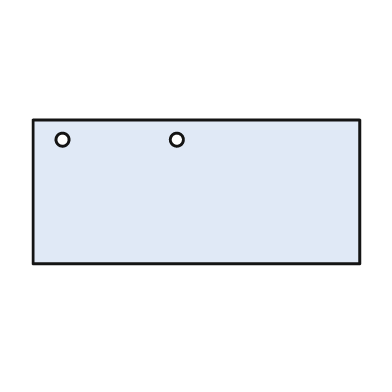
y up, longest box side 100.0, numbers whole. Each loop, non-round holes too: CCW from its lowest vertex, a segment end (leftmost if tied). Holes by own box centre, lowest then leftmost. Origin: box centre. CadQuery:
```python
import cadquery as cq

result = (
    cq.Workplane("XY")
    .moveTo(-50.0, -22.0)
    .lineTo(50.0, -22.0)
    .lineTo(50.0, 22.0)
    .lineTo(-50.0, 22.0)
    .close()
    .moveTo(-41.0, 16.0)
    .circle(2.0)
    .moveTo(-6.0, 16.0)
    .circle(2.0)
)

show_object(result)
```